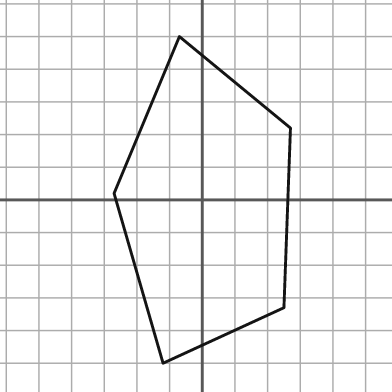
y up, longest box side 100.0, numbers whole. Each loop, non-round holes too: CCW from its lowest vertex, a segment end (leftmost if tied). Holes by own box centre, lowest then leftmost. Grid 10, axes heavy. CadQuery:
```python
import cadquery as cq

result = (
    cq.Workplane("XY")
    .moveTo(-12.0, -50.0)
    .lineTo(25.0, -33.0)
    .lineTo(27.0, 22.0)
    .lineTo(-7.0, 50.0)
    .lineTo(-27.0, 2.0)
    .close()
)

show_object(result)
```